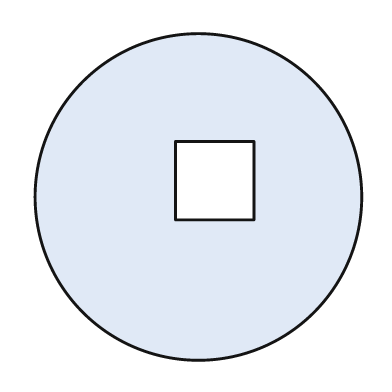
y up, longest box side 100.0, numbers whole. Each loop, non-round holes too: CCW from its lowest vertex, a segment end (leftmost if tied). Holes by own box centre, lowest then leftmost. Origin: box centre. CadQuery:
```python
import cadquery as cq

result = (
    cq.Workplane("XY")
    .moveTo(0.0, 0.0)
    .circle(50.0)
    .moveTo(-7.0, -7.0)
    .lineTo(17.0, -7.0)
    .lineTo(17.0, 17.0)
    .lineTo(-7.0, 17.0)
    .close()
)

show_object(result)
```